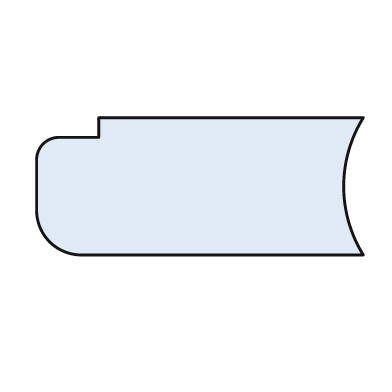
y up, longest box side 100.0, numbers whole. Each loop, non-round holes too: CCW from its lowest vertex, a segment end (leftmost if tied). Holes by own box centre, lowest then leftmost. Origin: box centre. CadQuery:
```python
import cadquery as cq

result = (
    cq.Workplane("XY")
    .moveTo(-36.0, -21.0)
    .lineTo(50.0, -21.0)
    .threePointArc((44.0, 0.0), (50.0, 21.0))
    .lineTo(-31.0, 21.0)
    .lineTo(-31.0, 15.0)
    .lineTo(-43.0, 15.0)
    .threePointArc((-48.0, 13.0), (-50.0, 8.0))
    .lineTo(-50.0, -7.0)
    .threePointArc((-46.0, -17.0), (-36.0, -21.0))
    .close()
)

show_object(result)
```